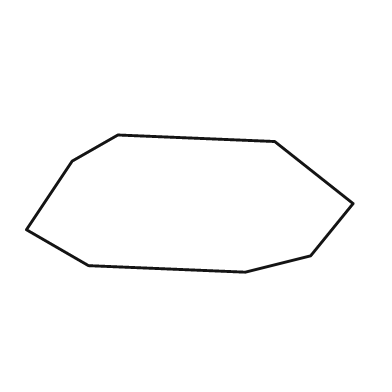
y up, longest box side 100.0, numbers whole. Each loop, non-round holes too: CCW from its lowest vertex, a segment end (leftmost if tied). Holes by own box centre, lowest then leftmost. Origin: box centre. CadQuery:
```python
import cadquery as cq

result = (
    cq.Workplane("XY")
    .moveTo(17.0, -21.0)
    .lineTo(37.0, -16.0)
    .lineTo(50.0, 0.0)
    .lineTo(26.0, 19.0)
    .lineTo(-22.0, 21.0)
    .lineTo(-36.0, 13.0)
    .lineTo(-50.0, -8.0)
    .lineTo(-31.0, -19.0)
    .close()
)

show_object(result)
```